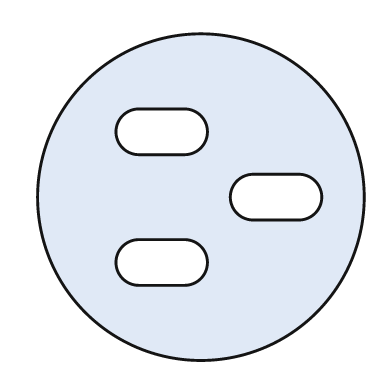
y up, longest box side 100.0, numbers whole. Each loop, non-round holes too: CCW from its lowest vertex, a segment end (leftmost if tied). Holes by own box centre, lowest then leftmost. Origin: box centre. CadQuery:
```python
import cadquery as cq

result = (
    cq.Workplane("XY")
    .moveTo(0.0, 0.0)
    .circle(50.0)
    .moveTo(-19.0, -27.0)
    .lineTo(-5.0, -27.0)
    .threePointArc((2.0, -20.0), (-5.0, -13.0))
    .lineTo(-19.0, -13.0)
    .threePointArc((-26.0, -20.0), (-19.0, -27.0))
    .close()
    .moveTo(16.0, -7.0)
    .lineTo(30.0, -7.0)
    .threePointArc((37.0, 0.0), (30.0, 7.0))
    .lineTo(16.0, 7.0)
    .threePointArc((9.0, 0.0), (16.0, -7.0))
    .close()
    .moveTo(-19.0, 13.0)
    .lineTo(-5.0, 13.0)
    .threePointArc((2.0, 20.0), (-5.0, 27.0))
    .lineTo(-19.0, 27.0)
    .threePointArc((-26.0, 20.0), (-19.0, 13.0))
    .close()
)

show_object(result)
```